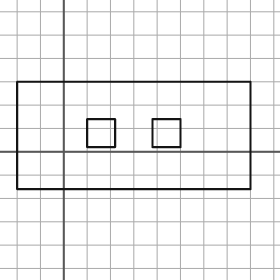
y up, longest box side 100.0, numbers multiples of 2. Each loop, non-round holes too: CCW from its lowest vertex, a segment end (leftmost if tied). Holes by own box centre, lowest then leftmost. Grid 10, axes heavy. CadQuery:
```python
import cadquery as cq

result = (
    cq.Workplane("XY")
    .moveTo(-20.0, -16.0)
    .lineTo(80.0, -16.0)
    .lineTo(80.0, 30.0)
    .lineTo(-20.0, 30.0)
    .close()
    .moveTo(10.0, 2.0)
    .lineTo(22.0, 2.0)
    .lineTo(22.0, 14.0)
    .lineTo(10.0, 14.0)
    .close()
    .moveTo(38.0, 2.0)
    .lineTo(50.0, 2.0)
    .lineTo(50.0, 14.0)
    .lineTo(38.0, 14.0)
    .close()
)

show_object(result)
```